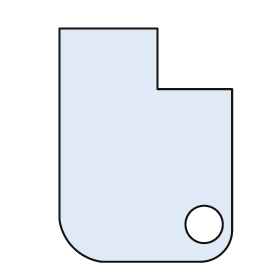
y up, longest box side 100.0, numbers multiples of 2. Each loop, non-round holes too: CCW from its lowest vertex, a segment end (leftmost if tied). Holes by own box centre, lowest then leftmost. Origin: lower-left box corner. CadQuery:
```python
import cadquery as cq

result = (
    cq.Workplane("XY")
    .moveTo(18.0, 0.0)
    .lineTo(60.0, 0.0)
    .threePointArc((70.0, 4.0), (74.0, 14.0))
    .lineTo(74.0, 74.0)
    .lineTo(42.0, 74.0)
    .lineTo(42.0, 100.0)
    .lineTo(0.0, 100.0)
    .lineTo(0.0, 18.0)
    .threePointArc((6.0, 6.0), (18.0, 0.0))
    .close()
    .moveTo(62.0, 16.0)
    .circle(8.0)
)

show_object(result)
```